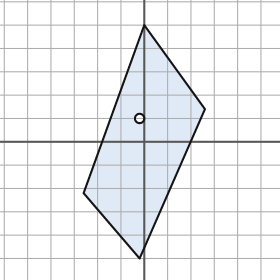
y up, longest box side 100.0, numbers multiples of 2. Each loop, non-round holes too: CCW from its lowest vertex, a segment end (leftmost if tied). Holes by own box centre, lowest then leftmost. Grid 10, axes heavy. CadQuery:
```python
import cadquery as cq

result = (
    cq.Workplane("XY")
    .moveTo(-2.0, -50.0)
    .lineTo(26.0, 14.0)
    .lineTo(0.0, 50.0)
    .lineTo(-26.0, -22.0)
    .close()
    .moveTo(-2.0, 10.0)
    .circle(2.0)
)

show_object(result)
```